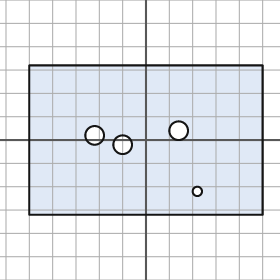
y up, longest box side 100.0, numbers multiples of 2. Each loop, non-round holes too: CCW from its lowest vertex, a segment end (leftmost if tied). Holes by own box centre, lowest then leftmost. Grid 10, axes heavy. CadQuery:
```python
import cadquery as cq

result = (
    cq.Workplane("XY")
    .moveTo(-50.0, -32.0)
    .lineTo(50.0, -32.0)
    .lineTo(50.0, 32.0)
    .lineTo(-50.0, 32.0)
    .close()
    .moveTo(22.0, -22.0)
    .circle(2.0)
    .moveTo(-10.0, -2.0)
    .circle(4.0)
    .moveTo(-22.0, 2.0)
    .circle(4.0)
    .moveTo(14.0, 4.0)
    .circle(4.0)
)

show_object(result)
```